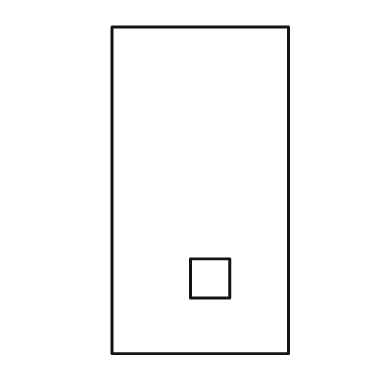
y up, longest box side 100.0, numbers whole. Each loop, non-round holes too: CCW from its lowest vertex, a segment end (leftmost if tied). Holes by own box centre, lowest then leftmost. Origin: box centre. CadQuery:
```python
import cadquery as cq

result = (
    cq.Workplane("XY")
    .moveTo(-27.0, -50.0)
    .lineTo(27.0, -50.0)
    .lineTo(27.0, 50.0)
    .lineTo(-27.0, 50.0)
    .close()
    .moveTo(-3.0, -33.0)
    .lineTo(9.0, -33.0)
    .lineTo(9.0, -21.0)
    .lineTo(-3.0, -21.0)
    .close()
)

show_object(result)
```